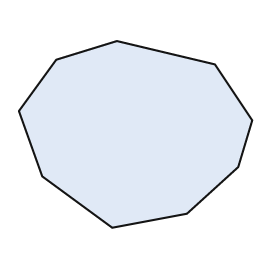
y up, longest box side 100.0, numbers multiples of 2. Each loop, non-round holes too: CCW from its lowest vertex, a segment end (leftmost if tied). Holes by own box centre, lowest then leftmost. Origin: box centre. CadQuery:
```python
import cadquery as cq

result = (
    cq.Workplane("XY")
    .moveTo(-10.0, -40.0)
    .lineTo(22.0, -34.0)
    .lineTo(44.0, -14.0)
    .lineTo(50.0, 6.0)
    .lineTo(34.0, 30.0)
    .lineTo(-8.0, 40.0)
    .lineTo(-34.0, 32.0)
    .lineTo(-50.0, 10.0)
    .lineTo(-40.0, -18.0)
    .close()
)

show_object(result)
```